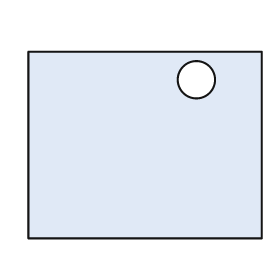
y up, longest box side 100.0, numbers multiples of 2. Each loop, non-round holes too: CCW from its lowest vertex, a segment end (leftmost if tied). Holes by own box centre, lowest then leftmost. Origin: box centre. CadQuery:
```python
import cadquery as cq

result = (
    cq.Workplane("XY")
    .moveTo(-50.0, -40.0)
    .lineTo(50.0, -40.0)
    .lineTo(50.0, 40.0)
    .lineTo(-50.0, 40.0)
    .close()
    .moveTo(22.0, 28.0)
    .circle(8.0)
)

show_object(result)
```